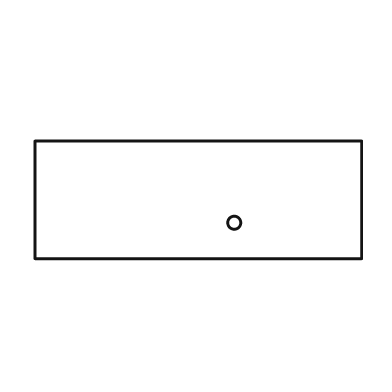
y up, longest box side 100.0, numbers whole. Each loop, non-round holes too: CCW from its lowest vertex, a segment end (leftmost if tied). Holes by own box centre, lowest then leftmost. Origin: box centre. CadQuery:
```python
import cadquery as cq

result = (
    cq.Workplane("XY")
    .moveTo(-50.0, -18.0)
    .lineTo(50.0, -18.0)
    .lineTo(50.0, 18.0)
    .lineTo(-50.0, 18.0)
    .close()
    .moveTo(11.0, -7.0)
    .circle(2.0)
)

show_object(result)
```